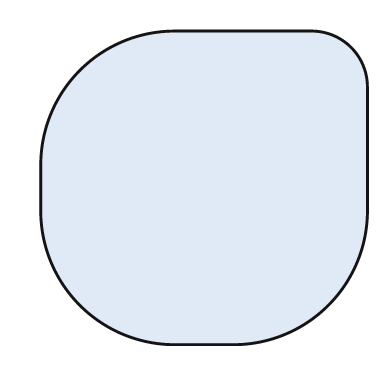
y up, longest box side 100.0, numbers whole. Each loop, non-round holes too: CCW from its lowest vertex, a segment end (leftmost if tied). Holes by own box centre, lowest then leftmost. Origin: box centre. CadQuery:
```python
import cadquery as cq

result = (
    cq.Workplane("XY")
    .moveTo(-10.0, -48.0)
    .lineTo(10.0, -48.0)
    .threePointArc((38.0, -36.0), (50.0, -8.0))
    .lineTo(50.0, 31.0)
    .threePointArc((45.0, 43.0), (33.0, 48.0))
    .lineTo(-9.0, 48.0)
    .threePointArc((-38.0, 36.0), (-50.0, 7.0))
    .lineTo(-50.0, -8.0)
    .threePointArc((-38.0, -36.0), (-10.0, -48.0))
    .close()
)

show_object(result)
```